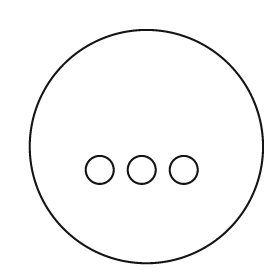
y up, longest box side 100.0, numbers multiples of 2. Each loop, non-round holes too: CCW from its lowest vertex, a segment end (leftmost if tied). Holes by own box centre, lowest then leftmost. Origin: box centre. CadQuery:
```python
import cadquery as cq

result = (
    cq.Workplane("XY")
    .moveTo(0.0, 0.0)
    .circle(50.0)
    .moveTo(-20.0, -10.0)
    .circle(6.0)
    .moveTo(-2.0, -10.0)
    .circle(6.0)
    .moveTo(16.0, -10.0)
    .circle(6.0)
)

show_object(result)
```